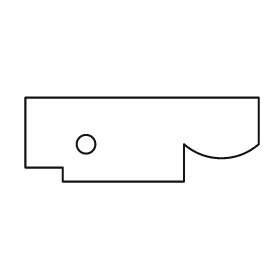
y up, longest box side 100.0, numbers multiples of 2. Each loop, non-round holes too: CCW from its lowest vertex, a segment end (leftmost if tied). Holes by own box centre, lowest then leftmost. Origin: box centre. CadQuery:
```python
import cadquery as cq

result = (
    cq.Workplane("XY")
    .moveTo(-34.0, -18.0)
    .lineTo(18.0, -18.0)
    .lineTo(18.0, -2.0)
    .threePointArc((34.0, -8.0), (50.0, -2.0))
    .lineTo(50.0, 18.0)
    .lineTo(-50.0, 18.0)
    .lineTo(-50.0, -12.0)
    .lineTo(-34.0, -12.0)
    .close()
    .moveTo(-24.0, -2.0)
    .circle(4.0)
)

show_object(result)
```